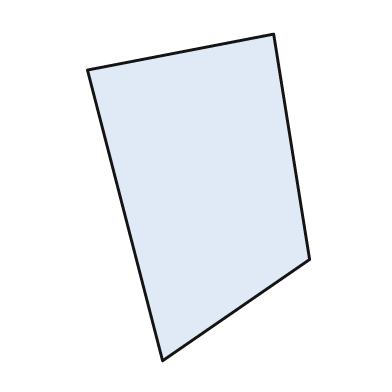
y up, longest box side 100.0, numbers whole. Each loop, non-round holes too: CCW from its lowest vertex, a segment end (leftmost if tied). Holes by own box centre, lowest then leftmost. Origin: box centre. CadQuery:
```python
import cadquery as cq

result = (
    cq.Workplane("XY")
    .moveTo(-11.0, -50.0)
    .lineTo(34.0, -19.0)
    .lineTo(23.0, 50.0)
    .lineTo(-34.0, 39.0)
    .close()
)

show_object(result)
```